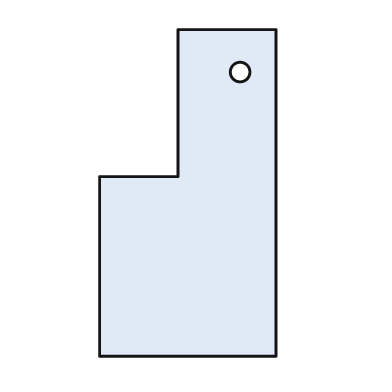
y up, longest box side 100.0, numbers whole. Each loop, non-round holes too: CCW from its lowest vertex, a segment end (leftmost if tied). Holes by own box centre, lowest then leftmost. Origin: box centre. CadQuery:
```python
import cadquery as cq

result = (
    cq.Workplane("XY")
    .moveTo(-27.0, -50.0)
    .lineTo(27.0, -50.0)
    .lineTo(27.0, 50.0)
    .lineTo(-3.0, 50.0)
    .lineTo(-3.0, 5.0)
    .lineTo(-27.0, 5.0)
    .close()
    .moveTo(16.0, 37.0)
    .circle(3.0)
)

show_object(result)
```